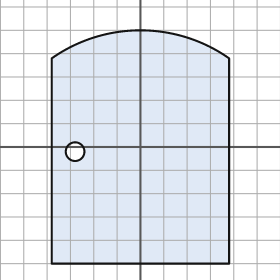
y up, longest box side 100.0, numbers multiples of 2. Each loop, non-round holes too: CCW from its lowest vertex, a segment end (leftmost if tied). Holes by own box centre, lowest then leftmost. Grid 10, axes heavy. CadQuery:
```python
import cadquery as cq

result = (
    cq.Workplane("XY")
    .moveTo(-38.0, -50.0)
    .lineTo(38.0, -50.0)
    .lineTo(38.0, 38.0)
    .threePointArc((0.0, 50.0), (-38.0, 38.0))
    .close()
    .moveTo(-28.0, -2.0)
    .circle(4.0)
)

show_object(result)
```